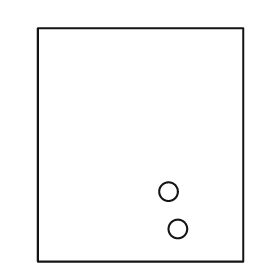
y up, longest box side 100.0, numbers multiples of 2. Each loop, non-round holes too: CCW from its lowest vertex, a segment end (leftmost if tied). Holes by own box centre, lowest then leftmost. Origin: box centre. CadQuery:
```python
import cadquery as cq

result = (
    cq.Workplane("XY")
    .moveTo(-44.0, -50.0)
    .lineTo(44.0, -50.0)
    .lineTo(44.0, 50.0)
    .lineTo(-44.0, 50.0)
    .close()
    .moveTo(16.0, -36.0)
    .circle(4.0)
    .moveTo(12.0, -20.0)
    .circle(4.0)
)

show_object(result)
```